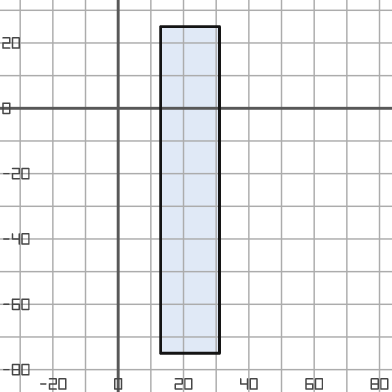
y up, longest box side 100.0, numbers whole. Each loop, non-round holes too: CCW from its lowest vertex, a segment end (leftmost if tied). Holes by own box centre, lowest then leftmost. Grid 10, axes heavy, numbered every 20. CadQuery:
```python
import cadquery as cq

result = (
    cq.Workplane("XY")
    .moveTo(13.0, -75.0)
    .lineTo(31.0, -75.0)
    .lineTo(31.0, 25.0)
    .lineTo(13.0, 25.0)
    .close()
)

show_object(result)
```